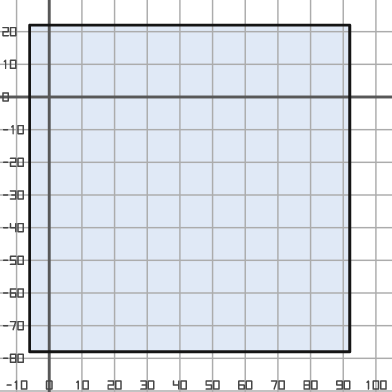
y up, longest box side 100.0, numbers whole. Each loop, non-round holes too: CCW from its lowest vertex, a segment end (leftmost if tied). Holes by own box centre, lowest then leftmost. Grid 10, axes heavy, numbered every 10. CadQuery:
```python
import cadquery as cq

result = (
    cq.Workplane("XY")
    .moveTo(-6.0, -78.0)
    .lineTo(92.0, -78.0)
    .lineTo(92.0, 22.0)
    .lineTo(-6.0, 22.0)
    .close()
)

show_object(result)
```